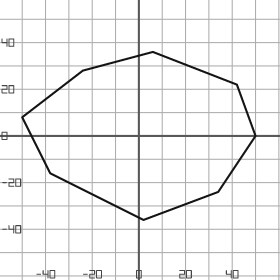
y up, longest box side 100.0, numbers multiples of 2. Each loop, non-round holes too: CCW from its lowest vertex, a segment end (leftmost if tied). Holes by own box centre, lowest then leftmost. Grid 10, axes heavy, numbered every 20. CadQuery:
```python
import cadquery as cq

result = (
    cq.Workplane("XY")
    .moveTo(2.0, -36.0)
    .lineTo(34.0, -24.0)
    .lineTo(50.0, 0.0)
    .lineTo(42.0, 22.0)
    .lineTo(6.0, 36.0)
    .lineTo(-24.0, 28.0)
    .lineTo(-50.0, 8.0)
    .lineTo(-38.0, -16.0)
    .close()
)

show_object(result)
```